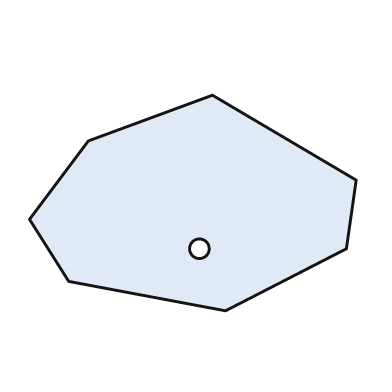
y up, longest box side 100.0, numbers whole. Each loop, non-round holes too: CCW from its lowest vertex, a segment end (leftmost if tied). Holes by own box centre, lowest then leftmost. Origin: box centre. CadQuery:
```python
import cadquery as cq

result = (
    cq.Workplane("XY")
    .moveTo(10.0, -33.0)
    .lineTo(47.0, -14.0)
    .lineTo(50.0, 7.0)
    .lineTo(6.0, 33.0)
    .lineTo(-32.0, 19.0)
    .lineTo(-50.0, -5.0)
    .lineTo(-38.0, -24.0)
    .close()
    .moveTo(2.0, -14.0)
    .circle(3.0)
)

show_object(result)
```